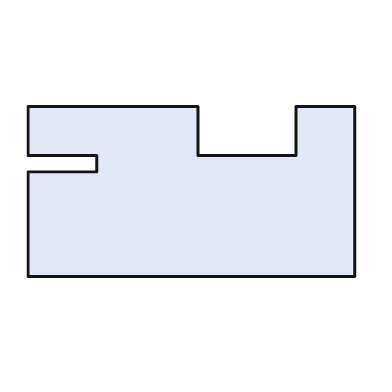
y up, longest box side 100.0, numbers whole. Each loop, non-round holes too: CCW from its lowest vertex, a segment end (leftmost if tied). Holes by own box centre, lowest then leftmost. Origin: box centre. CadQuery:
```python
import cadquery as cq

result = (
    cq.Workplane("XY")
    .moveTo(-50.0, -26.0)
    .lineTo(50.0, -26.0)
    .lineTo(50.0, 26.0)
    .lineTo(32.0, 26.0)
    .lineTo(32.0, 11.0)
    .lineTo(2.0, 11.0)
    .lineTo(2.0, 26.0)
    .lineTo(-50.0, 26.0)
    .lineTo(-50.0, 11.0)
    .lineTo(-29.0, 11.0)
    .lineTo(-29.0, 6.0)
    .lineTo(-50.0, 6.0)
    .close()
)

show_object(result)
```